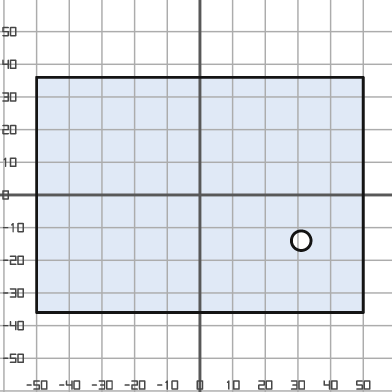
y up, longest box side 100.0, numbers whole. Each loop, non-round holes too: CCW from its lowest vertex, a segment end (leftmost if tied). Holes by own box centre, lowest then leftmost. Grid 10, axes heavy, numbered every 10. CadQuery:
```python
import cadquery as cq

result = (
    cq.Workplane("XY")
    .moveTo(-50.0, -36.0)
    .lineTo(50.0, -36.0)
    .lineTo(50.0, 36.0)
    .lineTo(-50.0, 36.0)
    .close()
    .moveTo(31.0, -14.0)
    .circle(3.0)
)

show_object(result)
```